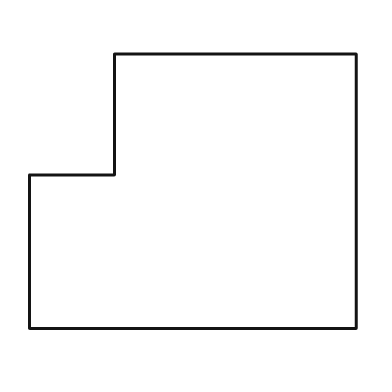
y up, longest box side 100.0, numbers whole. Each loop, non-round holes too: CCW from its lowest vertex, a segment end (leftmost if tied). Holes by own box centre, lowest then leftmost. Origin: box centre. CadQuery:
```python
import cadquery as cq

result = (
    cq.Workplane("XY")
    .moveTo(-50.0, -42.0)
    .lineTo(50.0, -42.0)
    .lineTo(50.0, 42.0)
    .lineTo(-24.0, 42.0)
    .lineTo(-24.0, 5.0)
    .lineTo(-50.0, 5.0)
    .close()
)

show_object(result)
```